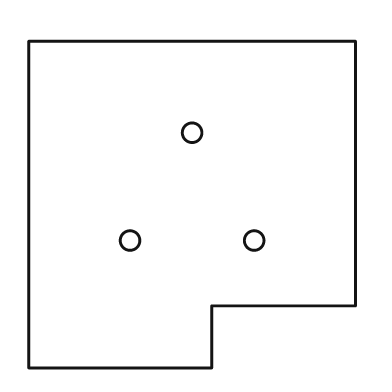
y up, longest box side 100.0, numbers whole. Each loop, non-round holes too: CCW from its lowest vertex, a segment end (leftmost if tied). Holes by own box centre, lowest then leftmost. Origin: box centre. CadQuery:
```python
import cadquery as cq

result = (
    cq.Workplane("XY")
    .moveTo(-50.0, -50.0)
    .lineTo(6.0, -50.0)
    .lineTo(6.0, -31.0)
    .lineTo(50.0, -31.0)
    .lineTo(50.0, 50.0)
    .lineTo(-50.0, 50.0)
    .close()
    .moveTo(-19.0, -11.0)
    .circle(3.0)
    .moveTo(19.0, -11.0)
    .circle(3.0)
    .moveTo(0.0, 22.0)
    .circle(3.0)
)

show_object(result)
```